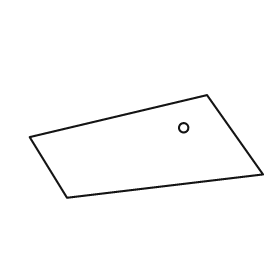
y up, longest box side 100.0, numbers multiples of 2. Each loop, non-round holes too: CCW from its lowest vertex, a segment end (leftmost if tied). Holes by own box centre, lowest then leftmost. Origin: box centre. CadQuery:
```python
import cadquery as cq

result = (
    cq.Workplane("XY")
    .moveTo(-34.0, -22.0)
    .lineTo(50.0, -12.0)
    .lineTo(26.0, 22.0)
    .lineTo(-50.0, 4.0)
    .close()
    .moveTo(16.0, 8.0)
    .circle(2.0)
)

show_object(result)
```